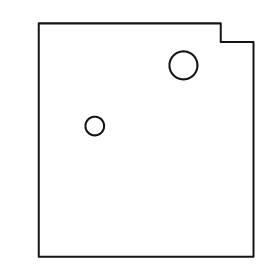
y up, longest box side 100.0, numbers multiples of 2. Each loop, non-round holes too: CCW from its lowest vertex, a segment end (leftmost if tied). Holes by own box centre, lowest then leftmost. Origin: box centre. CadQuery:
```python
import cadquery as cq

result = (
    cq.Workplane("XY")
    .moveTo(-46.0, -50.0)
    .lineTo(46.0, -50.0)
    .lineTo(46.0, 42.0)
    .lineTo(32.0, 42.0)
    .lineTo(32.0, 50.0)
    .lineTo(-46.0, 50.0)
    .close()
    .moveTo(-22.0, 6.0)
    .circle(4.0)
    .moveTo(16.0, 32.0)
    .circle(6.0)
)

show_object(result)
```